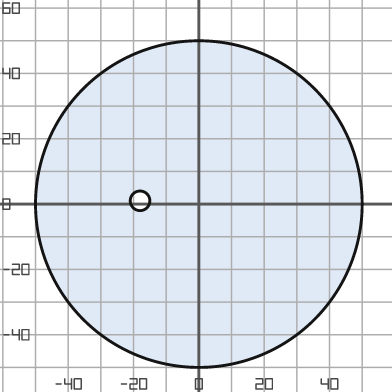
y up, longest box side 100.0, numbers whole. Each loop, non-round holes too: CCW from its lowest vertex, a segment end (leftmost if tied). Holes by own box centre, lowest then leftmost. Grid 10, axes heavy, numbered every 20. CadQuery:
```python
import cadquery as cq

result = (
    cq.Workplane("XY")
    .moveTo(0.0, 0.0)
    .circle(50.0)
    .moveTo(-18.0, 1.0)
    .circle(3.0)
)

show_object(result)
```